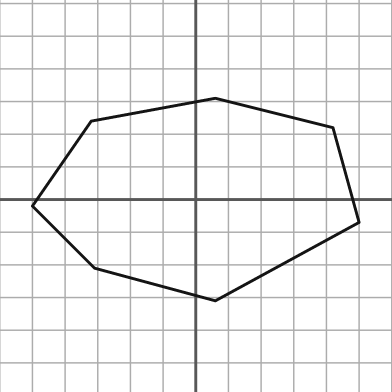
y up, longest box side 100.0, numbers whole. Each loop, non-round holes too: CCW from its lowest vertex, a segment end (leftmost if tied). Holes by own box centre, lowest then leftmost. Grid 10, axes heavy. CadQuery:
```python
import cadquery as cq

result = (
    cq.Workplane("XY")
    .moveTo(6.0, -31.0)
    .lineTo(50.0, -7.0)
    .lineTo(42.0, 22.0)
    .lineTo(6.0, 31.0)
    .lineTo(-32.0, 24.0)
    .lineTo(-50.0, -2.0)
    .lineTo(-31.0, -21.0)
    .close()
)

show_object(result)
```